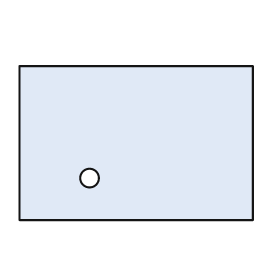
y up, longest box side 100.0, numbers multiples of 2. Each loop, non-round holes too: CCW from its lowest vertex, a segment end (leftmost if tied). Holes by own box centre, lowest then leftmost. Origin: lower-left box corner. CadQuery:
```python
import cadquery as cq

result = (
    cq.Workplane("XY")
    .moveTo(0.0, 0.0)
    .lineTo(100.0, 0.0)
    .lineTo(100.0, 66.0)
    .lineTo(0.0, 66.0)
    .close()
    .moveTo(30.0, 18.0)
    .circle(4.0)
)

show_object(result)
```